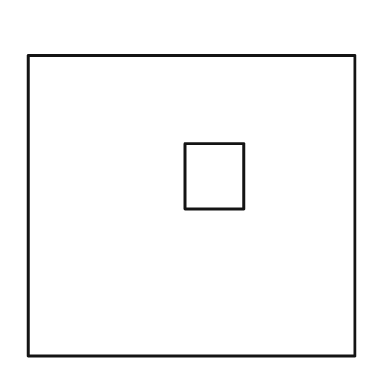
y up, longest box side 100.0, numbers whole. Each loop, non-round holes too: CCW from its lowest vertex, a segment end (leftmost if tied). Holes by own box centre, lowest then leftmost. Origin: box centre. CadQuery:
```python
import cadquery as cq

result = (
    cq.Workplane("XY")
    .moveTo(-50.0, -46.0)
    .lineTo(50.0, -46.0)
    .lineTo(50.0, 46.0)
    .lineTo(-50.0, 46.0)
    .close()
    .moveTo(-2.0, -1.0)
    .lineTo(16.0, -1.0)
    .lineTo(16.0, 19.0)
    .lineTo(-2.0, 19.0)
    .close()
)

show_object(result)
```